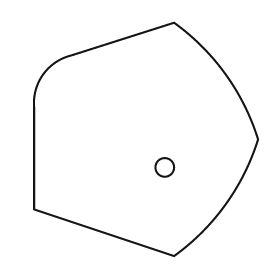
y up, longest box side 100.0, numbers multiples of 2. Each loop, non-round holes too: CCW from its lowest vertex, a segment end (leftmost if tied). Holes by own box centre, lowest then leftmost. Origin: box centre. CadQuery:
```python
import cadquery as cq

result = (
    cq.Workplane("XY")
    .moveTo(12.0, -50.0)
    .threePointArc((34.0, -28.0), (48.0, 0.0))
    .threePointArc((34.0, 28.0), (12.0, 50.0))
    .lineTo(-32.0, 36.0)
    .threePointArc((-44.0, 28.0), (-48.0, 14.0))
    .lineTo(-48.0, -30.0)
    .close()
    .moveTo(8.0, -12.0)
    .circle(4.0)
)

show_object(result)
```